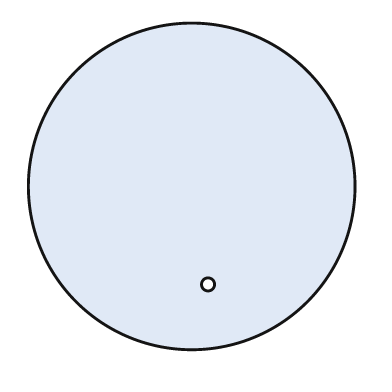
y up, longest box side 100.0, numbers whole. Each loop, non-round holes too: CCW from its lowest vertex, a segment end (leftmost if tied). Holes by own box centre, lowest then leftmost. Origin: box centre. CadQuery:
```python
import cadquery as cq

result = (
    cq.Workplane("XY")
    .moveTo(0.0, 0.0)
    .circle(50.0)
    .moveTo(5.0, -30.0)
    .circle(2.0)
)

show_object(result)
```